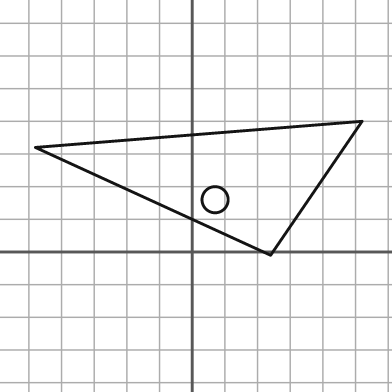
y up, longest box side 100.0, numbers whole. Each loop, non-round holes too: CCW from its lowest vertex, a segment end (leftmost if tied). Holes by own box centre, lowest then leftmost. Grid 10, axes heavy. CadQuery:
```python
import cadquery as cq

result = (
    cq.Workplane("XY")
    .moveTo(24.0, -1.0)
    .lineTo(52.0, 40.0)
    .lineTo(-48.0, 32.0)
    .close()
    .moveTo(7.0, 16.0)
    .circle(4.0)
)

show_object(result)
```